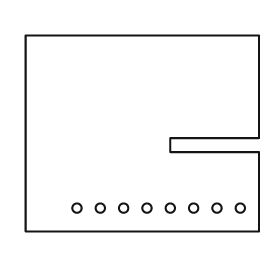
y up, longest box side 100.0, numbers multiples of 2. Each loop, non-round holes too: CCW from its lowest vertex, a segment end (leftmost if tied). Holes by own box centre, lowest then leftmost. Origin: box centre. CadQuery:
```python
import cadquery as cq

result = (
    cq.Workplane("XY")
    .moveTo(-50.0, -42.0)
    .lineTo(50.0, -42.0)
    .lineTo(50.0, -8.0)
    .lineTo(12.0, -8.0)
    .lineTo(12.0, -2.0)
    .lineTo(50.0, -2.0)
    .lineTo(50.0, 42.0)
    .lineTo(-50.0, 42.0)
    .close()
    .moveTo(-28.0, -32.0)
    .circle(2.0)
    .moveTo(-18.0, -32.0)
    .circle(2.0)
    .moveTo(-8.0, -32.0)
    .circle(2.0)
    .moveTo(2.0, -32.0)
    .circle(2.0)
    .moveTo(12.0, -32.0)
    .circle(2.0)
    .moveTo(22.0, -32.0)
    .circle(2.0)
    .moveTo(32.0, -32.0)
    .circle(2.0)
    .moveTo(42.0, -32.0)
    .circle(2.0)
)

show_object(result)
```